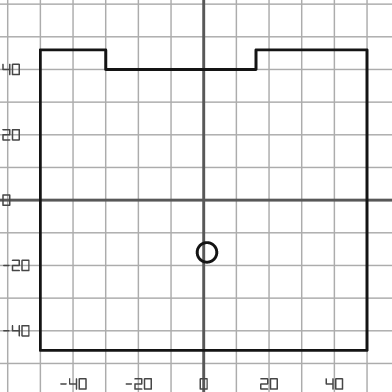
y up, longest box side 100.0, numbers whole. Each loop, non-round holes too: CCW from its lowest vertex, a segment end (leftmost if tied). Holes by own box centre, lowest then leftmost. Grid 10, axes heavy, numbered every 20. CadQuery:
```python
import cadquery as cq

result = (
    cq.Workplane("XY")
    .moveTo(-50.0, -46.0)
    .lineTo(50.0, -46.0)
    .lineTo(50.0, 46.0)
    .lineTo(16.0, 46.0)
    .lineTo(16.0, 40.0)
    .lineTo(-30.0, 40.0)
    .lineTo(-30.0, 46.0)
    .lineTo(-50.0, 46.0)
    .close()
    .moveTo(1.0, -16.0)
    .circle(3.0)
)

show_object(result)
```